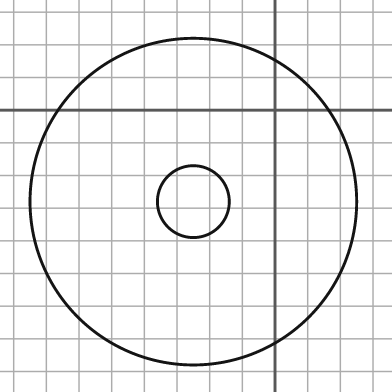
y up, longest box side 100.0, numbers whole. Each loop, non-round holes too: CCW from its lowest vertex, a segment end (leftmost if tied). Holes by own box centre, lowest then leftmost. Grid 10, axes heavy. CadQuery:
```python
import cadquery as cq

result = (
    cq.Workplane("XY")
    .moveTo(-25.0, -28.0)
    .circle(50.0)
    .moveTo(-25.0, -28.0)
    .circle(11.0)
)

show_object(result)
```